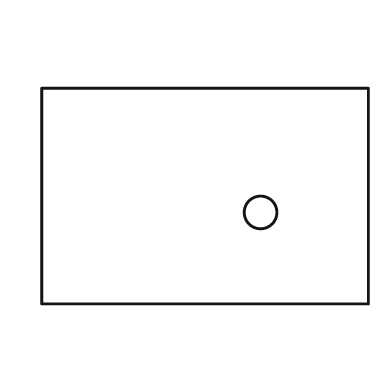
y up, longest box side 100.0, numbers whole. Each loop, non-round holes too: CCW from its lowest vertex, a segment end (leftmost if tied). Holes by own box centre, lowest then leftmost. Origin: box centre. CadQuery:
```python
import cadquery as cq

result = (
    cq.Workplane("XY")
    .moveTo(-50.0, -33.0)
    .lineTo(50.0, -33.0)
    .lineTo(50.0, 33.0)
    .lineTo(-50.0, 33.0)
    .close()
    .moveTo(17.0, -5.0)
    .circle(5.0)
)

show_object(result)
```